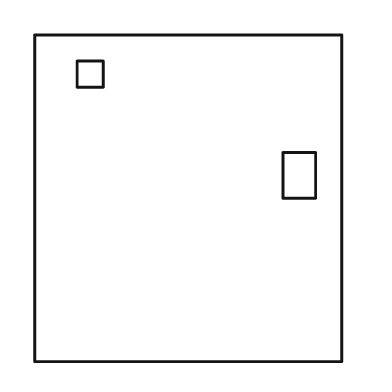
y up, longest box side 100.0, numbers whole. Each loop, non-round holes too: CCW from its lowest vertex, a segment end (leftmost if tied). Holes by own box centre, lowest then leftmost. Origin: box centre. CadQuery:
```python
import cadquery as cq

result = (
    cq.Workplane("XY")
    .moveTo(-47.0, -50.0)
    .lineTo(47.0, -50.0)
    .lineTo(47.0, 50.0)
    .lineTo(-47.0, 50.0)
    .close()
    .moveTo(29.0, 0.0)
    .lineTo(39.0, 0.0)
    .lineTo(39.0, 14.0)
    .lineTo(29.0, 14.0)
    .close()
    .moveTo(-34.0, 34.0)
    .lineTo(-26.0, 34.0)
    .lineTo(-26.0, 42.0)
    .lineTo(-34.0, 42.0)
    .close()
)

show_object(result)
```